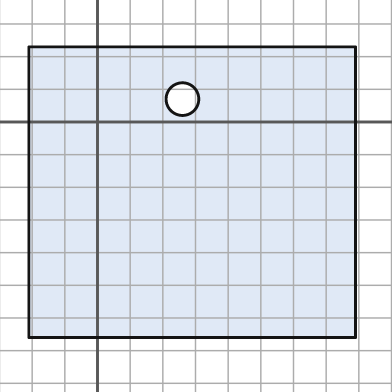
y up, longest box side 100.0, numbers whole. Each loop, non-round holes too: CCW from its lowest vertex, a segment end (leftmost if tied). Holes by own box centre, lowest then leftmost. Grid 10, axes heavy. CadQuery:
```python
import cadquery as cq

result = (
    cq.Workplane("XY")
    .moveTo(-21.0, -66.0)
    .lineTo(79.0, -66.0)
    .lineTo(79.0, 23.0)
    .lineTo(-21.0, 23.0)
    .close()
    .moveTo(26.0, 7.0)
    .circle(5.0)
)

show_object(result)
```